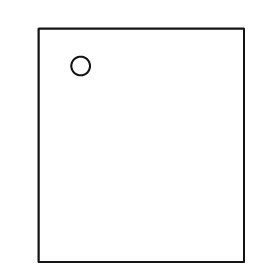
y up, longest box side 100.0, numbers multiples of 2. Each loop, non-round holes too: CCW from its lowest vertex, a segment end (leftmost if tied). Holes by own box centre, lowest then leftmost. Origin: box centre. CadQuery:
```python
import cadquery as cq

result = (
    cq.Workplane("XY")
    .moveTo(-44.0, -50.0)
    .lineTo(44.0, -50.0)
    .lineTo(44.0, 50.0)
    .lineTo(-44.0, 50.0)
    .close()
    .moveTo(-26.0, 34.0)
    .circle(4.0)
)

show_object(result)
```